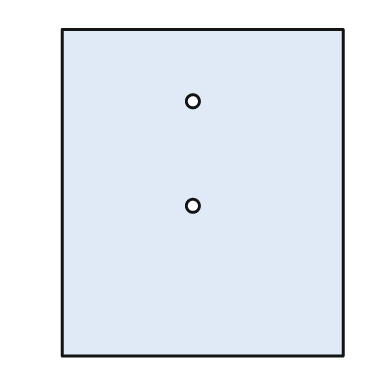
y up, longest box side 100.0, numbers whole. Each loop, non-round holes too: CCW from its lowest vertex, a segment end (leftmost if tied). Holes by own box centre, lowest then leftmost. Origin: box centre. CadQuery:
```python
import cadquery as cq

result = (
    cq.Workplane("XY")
    .moveTo(-43.0, -50.0)
    .lineTo(43.0, -50.0)
    .lineTo(43.0, 50.0)
    .lineTo(-43.0, 50.0)
    .close()
    .moveTo(-3.0, -4.0)
    .circle(2.0)
    .moveTo(-3.0, 28.0)
    .circle(2.0)
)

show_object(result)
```